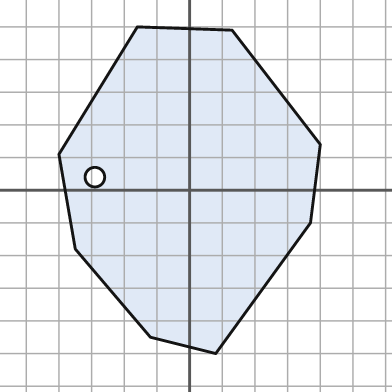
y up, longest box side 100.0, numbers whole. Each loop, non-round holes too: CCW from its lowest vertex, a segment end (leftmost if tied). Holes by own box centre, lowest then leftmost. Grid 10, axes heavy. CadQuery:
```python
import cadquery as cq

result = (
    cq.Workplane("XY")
    .moveTo(8.0, -50.0)
    .lineTo(37.0, -10.0)
    .lineTo(40.0, 14.0)
    .lineTo(13.0, 49.0)
    .lineTo(-16.0, 50.0)
    .lineTo(-40.0, 11.0)
    .lineTo(-35.0, -18.0)
    .lineTo(-12.0, -45.0)
    .close()
    .moveTo(-29.0, 4.0)
    .circle(3.0)
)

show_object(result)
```